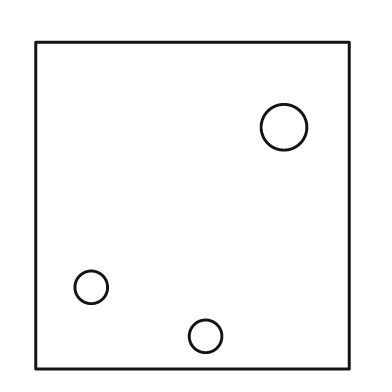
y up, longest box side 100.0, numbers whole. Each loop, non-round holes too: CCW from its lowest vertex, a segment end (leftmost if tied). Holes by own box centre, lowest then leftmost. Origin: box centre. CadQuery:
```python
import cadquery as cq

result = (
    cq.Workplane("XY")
    .moveTo(-48.0, -50.0)
    .lineTo(48.0, -50.0)
    .lineTo(48.0, 50.0)
    .lineTo(-48.0, 50.0)
    .close()
    .moveTo(4.0, -40.0)
    .circle(5.0)
    .moveTo(-31.0, -25.0)
    .circle(5.0)
    .moveTo(28.0, 24.0)
    .circle(7.0)
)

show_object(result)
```